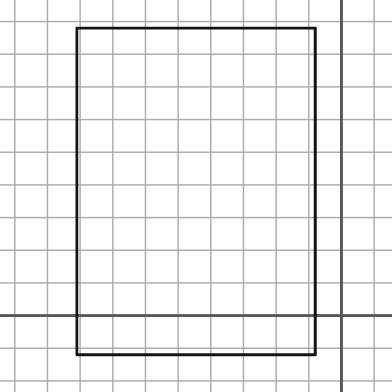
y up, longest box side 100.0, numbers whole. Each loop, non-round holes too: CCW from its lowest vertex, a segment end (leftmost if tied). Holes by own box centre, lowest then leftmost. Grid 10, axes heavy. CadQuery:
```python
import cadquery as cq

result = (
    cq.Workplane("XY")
    .moveTo(-81.0, -12.0)
    .lineTo(-8.0, -12.0)
    .lineTo(-8.0, 88.0)
    .lineTo(-81.0, 88.0)
    .close()
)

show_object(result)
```